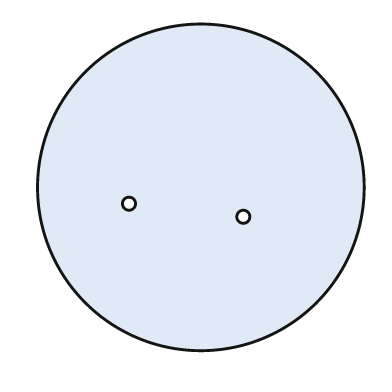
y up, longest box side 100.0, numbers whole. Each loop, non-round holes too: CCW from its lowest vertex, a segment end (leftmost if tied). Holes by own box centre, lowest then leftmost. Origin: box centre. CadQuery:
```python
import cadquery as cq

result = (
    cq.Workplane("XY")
    .moveTo(0.0, 0.0)
    .circle(50.0)
    .moveTo(13.0, -9.0)
    .circle(2.0)
    .moveTo(-22.0, -5.0)
    .circle(2.0)
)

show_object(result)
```